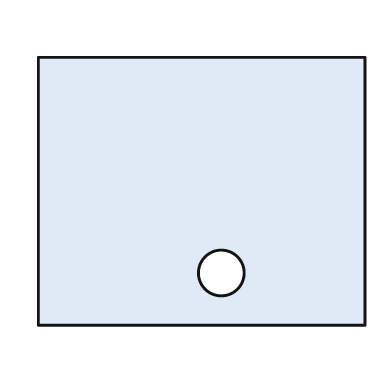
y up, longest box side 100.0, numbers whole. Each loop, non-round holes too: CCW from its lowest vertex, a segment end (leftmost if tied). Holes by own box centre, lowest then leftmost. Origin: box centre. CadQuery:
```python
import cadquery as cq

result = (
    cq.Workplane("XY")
    .moveTo(-50.0, -41.0)
    .lineTo(50.0, -41.0)
    .lineTo(50.0, 41.0)
    .lineTo(-50.0, 41.0)
    .close()
    .moveTo(6.0, -25.0)
    .circle(7.0)
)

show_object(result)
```